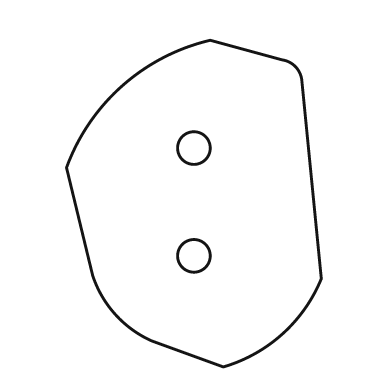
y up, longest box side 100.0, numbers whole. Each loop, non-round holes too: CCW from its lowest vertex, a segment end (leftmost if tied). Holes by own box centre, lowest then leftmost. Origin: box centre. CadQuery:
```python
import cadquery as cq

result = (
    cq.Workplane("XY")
    .moveTo(9.0, -50.0)
    .threePointArc((27.0, -40.0), (39.0, -23.0))
    .lineTo(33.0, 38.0)
    .threePointArc((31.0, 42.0), (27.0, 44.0))
    .lineTo(5.0, 50.0)
    .threePointArc((-22.0, 36.0), (-39.0, 11.0))
    .lineTo(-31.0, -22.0)
    .threePointArc((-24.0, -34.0), (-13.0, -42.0))
    .close()
    .moveTo(0.0, -16.0)
    .circle(5.0)
    .moveTo(0.0, 17.0)
    .circle(5.0)
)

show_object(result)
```